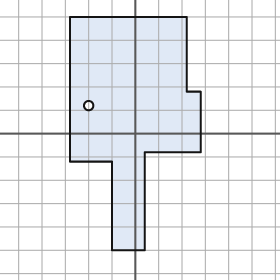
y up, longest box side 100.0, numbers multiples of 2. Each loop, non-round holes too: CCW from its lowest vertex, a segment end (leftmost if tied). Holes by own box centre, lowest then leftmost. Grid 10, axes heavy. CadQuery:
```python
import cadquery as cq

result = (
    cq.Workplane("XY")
    .moveTo(-10.0, -50.0)
    .lineTo(4.0, -50.0)
    .lineTo(4.0, -8.0)
    .lineTo(28.0, -8.0)
    .lineTo(28.0, 18.0)
    .lineTo(22.0, 18.0)
    .lineTo(22.0, 50.0)
    .lineTo(-28.0, 50.0)
    .lineTo(-28.0, -12.0)
    .lineTo(-10.0, -12.0)
    .close()
    .moveTo(-20.0, 12.0)
    .circle(2.0)
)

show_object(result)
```